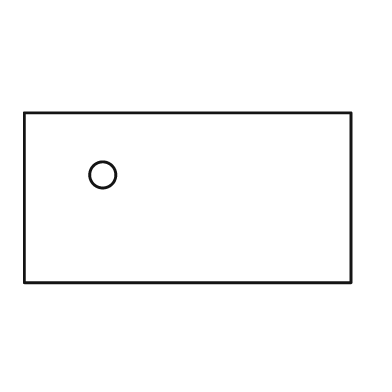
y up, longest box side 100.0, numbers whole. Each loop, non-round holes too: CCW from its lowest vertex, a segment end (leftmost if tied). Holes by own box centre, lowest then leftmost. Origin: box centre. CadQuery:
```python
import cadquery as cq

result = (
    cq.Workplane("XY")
    .moveTo(-50.0, -26.0)
    .lineTo(50.0, -26.0)
    .lineTo(50.0, 26.0)
    .lineTo(-50.0, 26.0)
    .close()
    .moveTo(-26.0, 7.0)
    .circle(4.0)
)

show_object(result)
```